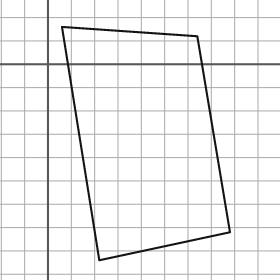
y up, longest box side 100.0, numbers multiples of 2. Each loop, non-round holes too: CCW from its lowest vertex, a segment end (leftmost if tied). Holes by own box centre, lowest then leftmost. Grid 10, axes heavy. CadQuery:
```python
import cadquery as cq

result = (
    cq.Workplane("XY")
    .moveTo(22.0, -84.0)
    .lineTo(78.0, -72.0)
    .lineTo(64.0, 12.0)
    .lineTo(6.0, 16.0)
    .close()
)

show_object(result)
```